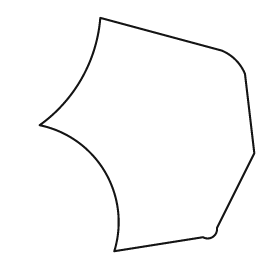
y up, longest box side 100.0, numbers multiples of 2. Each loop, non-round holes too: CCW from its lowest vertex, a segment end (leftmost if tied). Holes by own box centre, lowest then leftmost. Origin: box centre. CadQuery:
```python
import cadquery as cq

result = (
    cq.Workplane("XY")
    .moveTo(-14.0, -50.0)
    .lineTo(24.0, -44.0)
    .threePointArc((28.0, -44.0), (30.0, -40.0))
    .lineTo(46.0, -8.0)
    .lineTo(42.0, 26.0)
    .threePointArc((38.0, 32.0), (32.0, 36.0))
    .lineTo(-20.0, 50.0)
    .threePointArc((-28.0, 24.0), (-46.0, 4.0))
    .threePointArc((-18.0, -16.0), (-14.0, -50.0))
    .close()
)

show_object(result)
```